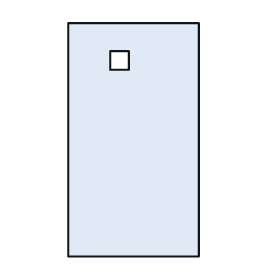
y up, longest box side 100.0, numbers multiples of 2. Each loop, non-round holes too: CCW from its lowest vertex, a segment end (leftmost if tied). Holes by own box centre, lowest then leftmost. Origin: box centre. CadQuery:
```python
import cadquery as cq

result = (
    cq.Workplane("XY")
    .moveTo(-28.0, -50.0)
    .lineTo(28.0, -50.0)
    .lineTo(28.0, 50.0)
    .lineTo(-28.0, 50.0)
    .close()
    .moveTo(-10.0, 30.0)
    .lineTo(-2.0, 30.0)
    .lineTo(-2.0, 38.0)
    .lineTo(-10.0, 38.0)
    .close()
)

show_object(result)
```